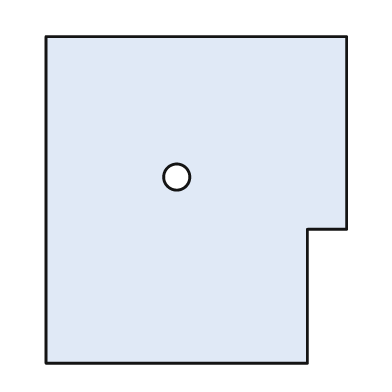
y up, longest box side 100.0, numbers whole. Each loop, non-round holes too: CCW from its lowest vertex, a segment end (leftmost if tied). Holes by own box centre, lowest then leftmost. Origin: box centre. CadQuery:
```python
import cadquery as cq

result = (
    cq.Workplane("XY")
    .moveTo(-46.0, -50.0)
    .lineTo(34.0, -50.0)
    .lineTo(34.0, -9.0)
    .lineTo(46.0, -9.0)
    .lineTo(46.0, 50.0)
    .lineTo(-46.0, 50.0)
    .close()
    .moveTo(-6.0, 7.0)
    .circle(4.0)
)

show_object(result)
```